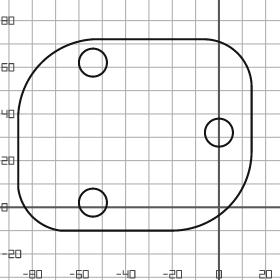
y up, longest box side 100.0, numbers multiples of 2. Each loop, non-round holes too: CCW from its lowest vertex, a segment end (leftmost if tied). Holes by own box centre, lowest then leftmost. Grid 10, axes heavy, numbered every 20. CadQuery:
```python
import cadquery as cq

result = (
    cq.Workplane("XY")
    .moveTo(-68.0, -10.0)
    .lineTo(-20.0, -10.0)
    .threePointArc((4.0, 0.0), (14.0, 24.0))
    .lineTo(14.0, 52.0)
    .threePointArc((8.0, 66.0), (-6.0, 72.0))
    .lineTo(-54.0, 72.0)
    .threePointArc((-76.0, 62.0), (-86.0, 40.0))
    .lineTo(-86.0, 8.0)
    .threePointArc((-80.0, -4.0), (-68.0, -10.0))
    .close()
    .moveTo(-54.0, 2.0)
    .circle(6.0)
    .moveTo(0.0, 32.0)
    .circle(6.0)
    .moveTo(-54.0, 62.0)
    .circle(6.0)
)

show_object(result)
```